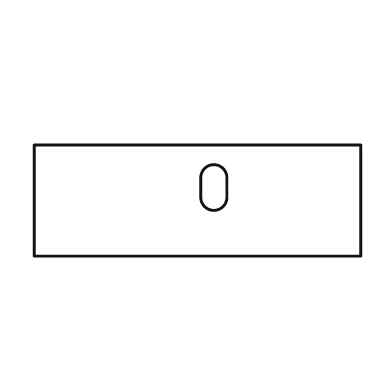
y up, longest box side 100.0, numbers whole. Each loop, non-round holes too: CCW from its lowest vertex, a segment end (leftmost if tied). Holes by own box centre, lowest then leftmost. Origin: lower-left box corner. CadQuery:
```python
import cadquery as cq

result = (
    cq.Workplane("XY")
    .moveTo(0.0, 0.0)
    .lineTo(100.0, 0.0)
    .lineTo(100.0, 34.0)
    .lineTo(0.0, 34.0)
    .close()
    .moveTo(51.0, 18.0)
    .threePointArc((55.0, 14.0), (59.0, 18.0))
    .lineTo(59.0, 24.0)
    .threePointArc((55.0, 28.0), (51.0, 24.0))
    .close()
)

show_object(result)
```